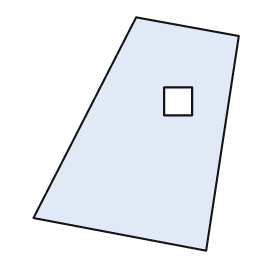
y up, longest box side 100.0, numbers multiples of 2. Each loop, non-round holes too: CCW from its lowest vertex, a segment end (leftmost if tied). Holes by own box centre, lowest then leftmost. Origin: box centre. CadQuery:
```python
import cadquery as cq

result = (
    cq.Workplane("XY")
    .moveTo(30.0, -50.0)
    .lineTo(44.0, 42.0)
    .lineTo(0.0, 50.0)
    .lineTo(-44.0, -36.0)
    .close()
    .moveTo(12.0, 8.0)
    .lineTo(24.0, 8.0)
    .lineTo(24.0, 20.0)
    .lineTo(12.0, 20.0)
    .close()
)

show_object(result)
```